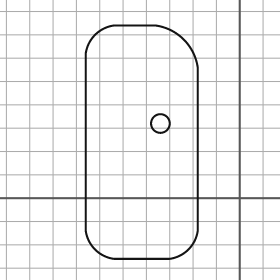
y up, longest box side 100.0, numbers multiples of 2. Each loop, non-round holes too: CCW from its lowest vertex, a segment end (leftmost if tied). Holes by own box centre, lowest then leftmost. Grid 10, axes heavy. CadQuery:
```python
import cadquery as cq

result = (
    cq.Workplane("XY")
    .moveTo(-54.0, -26.0)
    .lineTo(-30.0, -26.0)
    .threePointArc((-22.0, -22.0), (-18.0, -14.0))
    .lineTo(-18.0, 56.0)
    .threePointArc((-24.0, 68.0), (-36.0, 74.0))
    .lineTo(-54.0, 74.0)
    .threePointArc((-62.0, 70.0), (-66.0, 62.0))
    .lineTo(-66.0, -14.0)
    .threePointArc((-62.0, -22.0), (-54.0, -26.0))
    .close()
    .moveTo(-34.0, 32.0)
    .circle(4.0)
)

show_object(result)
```